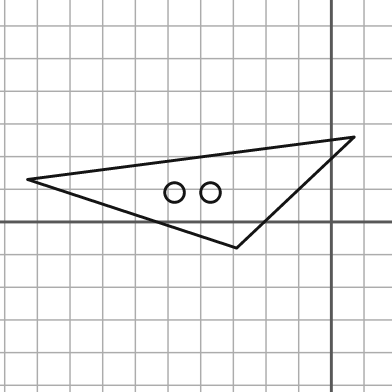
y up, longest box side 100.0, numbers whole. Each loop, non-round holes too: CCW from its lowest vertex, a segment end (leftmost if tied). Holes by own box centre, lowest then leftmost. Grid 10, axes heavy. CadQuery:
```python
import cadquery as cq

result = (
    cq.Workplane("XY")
    .moveTo(-29.0, -8.0)
    .lineTo(7.0, 26.0)
    .lineTo(-93.0, 13.0)
    .close()
    .moveTo(-48.0, 9.0)
    .circle(3.0)
    .moveTo(-37.0, 9.0)
    .circle(3.0)
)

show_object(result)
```